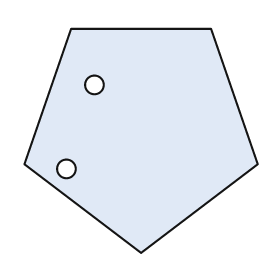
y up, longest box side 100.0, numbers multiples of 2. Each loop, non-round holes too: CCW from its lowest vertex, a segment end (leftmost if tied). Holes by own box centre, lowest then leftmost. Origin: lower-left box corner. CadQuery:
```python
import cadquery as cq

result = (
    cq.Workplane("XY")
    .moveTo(50.0, 0.0)
    .lineTo(100.0, 38.0)
    .lineTo(80.0, 96.0)
    .lineTo(20.0, 96.0)
    .lineTo(0.0, 38.0)
    .close()
    .moveTo(18.0, 36.0)
    .circle(4.0)
    .moveTo(30.0, 72.0)
    .circle(4.0)
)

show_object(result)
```